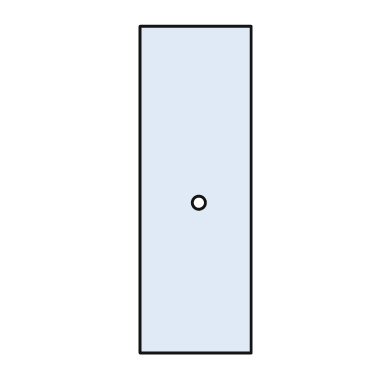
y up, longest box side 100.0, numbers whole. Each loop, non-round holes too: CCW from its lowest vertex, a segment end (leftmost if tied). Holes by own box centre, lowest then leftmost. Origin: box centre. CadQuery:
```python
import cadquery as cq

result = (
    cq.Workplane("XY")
    .moveTo(-17.0, -50.0)
    .lineTo(17.0, -50.0)
    .lineTo(17.0, 50.0)
    .lineTo(-17.0, 50.0)
    .close()
    .moveTo(1.0, -4.0)
    .circle(2.0)
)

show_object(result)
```